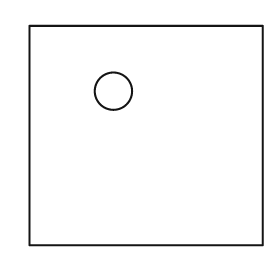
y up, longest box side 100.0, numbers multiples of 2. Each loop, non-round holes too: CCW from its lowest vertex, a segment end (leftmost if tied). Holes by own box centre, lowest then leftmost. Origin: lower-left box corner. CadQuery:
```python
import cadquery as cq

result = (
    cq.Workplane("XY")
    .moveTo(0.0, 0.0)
    .lineTo(100.0, 0.0)
    .lineTo(100.0, 94.0)
    .lineTo(0.0, 94.0)
    .close()
    .moveTo(36.0, 66.0)
    .circle(8.0)
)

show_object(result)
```